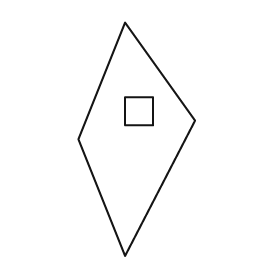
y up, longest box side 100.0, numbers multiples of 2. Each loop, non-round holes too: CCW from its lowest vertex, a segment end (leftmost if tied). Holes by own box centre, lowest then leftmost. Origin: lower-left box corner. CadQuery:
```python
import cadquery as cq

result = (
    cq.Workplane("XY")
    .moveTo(20.0, 0.0)
    .lineTo(50.0, 58.0)
    .lineTo(20.0, 100.0)
    .lineTo(0.0, 50.0)
    .close()
    .moveTo(20.0, 56.0)
    .lineTo(32.0, 56.0)
    .lineTo(32.0, 68.0)
    .lineTo(20.0, 68.0)
    .close()
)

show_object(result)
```